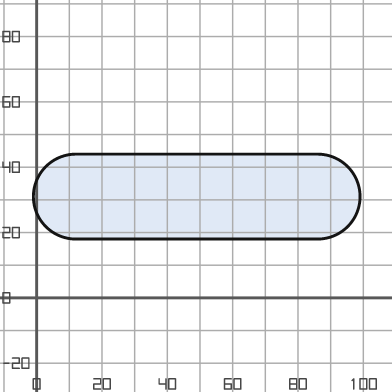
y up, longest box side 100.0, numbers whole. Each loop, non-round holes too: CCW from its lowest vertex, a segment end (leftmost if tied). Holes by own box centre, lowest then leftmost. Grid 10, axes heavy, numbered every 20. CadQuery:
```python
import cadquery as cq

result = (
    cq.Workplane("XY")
    .moveTo(12.0, 18.0)
    .lineTo(86.0, 18.0)
    .threePointArc((99.0, 31.0), (86.0, 44.0))
    .lineTo(12.0, 44.0)
    .threePointArc((-1.0, 31.0), (12.0, 18.0))
    .close()
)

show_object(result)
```